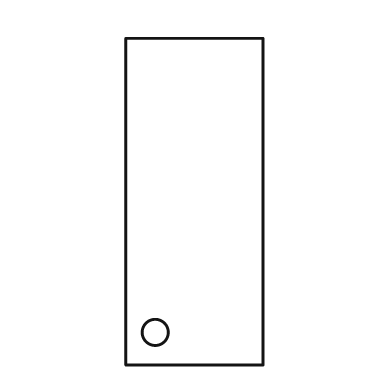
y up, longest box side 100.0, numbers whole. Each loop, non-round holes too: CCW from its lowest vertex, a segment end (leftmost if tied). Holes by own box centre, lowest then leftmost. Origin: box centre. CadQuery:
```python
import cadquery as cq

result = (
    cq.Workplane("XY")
    .moveTo(-21.0, -50.0)
    .lineTo(21.0, -50.0)
    .lineTo(21.0, 50.0)
    .lineTo(-21.0, 50.0)
    .close()
    .moveTo(-12.0, -40.0)
    .circle(4.0)
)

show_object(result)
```